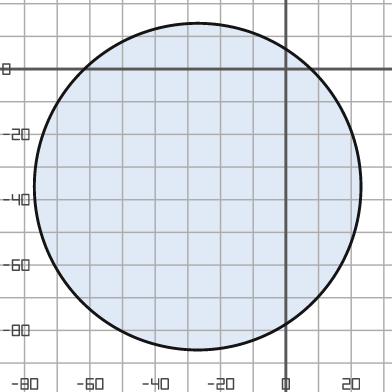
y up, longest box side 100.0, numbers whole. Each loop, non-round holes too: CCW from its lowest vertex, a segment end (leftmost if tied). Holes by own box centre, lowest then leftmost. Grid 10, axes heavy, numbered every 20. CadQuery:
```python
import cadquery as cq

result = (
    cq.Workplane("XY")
    .moveTo(-27.0, -36.0)
    .circle(50.0)
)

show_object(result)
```